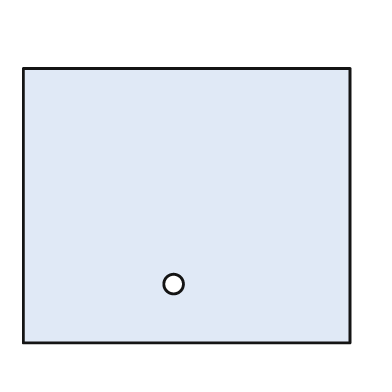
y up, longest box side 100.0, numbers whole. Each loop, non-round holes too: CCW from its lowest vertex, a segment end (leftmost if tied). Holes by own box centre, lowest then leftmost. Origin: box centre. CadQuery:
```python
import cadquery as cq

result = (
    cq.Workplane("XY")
    .moveTo(-50.0, -42.0)
    .lineTo(50.0, -42.0)
    .lineTo(50.0, 42.0)
    .lineTo(-50.0, 42.0)
    .close()
    .moveTo(-4.0, -24.0)
    .circle(3.0)
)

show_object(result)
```